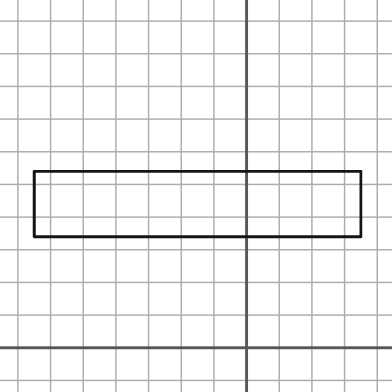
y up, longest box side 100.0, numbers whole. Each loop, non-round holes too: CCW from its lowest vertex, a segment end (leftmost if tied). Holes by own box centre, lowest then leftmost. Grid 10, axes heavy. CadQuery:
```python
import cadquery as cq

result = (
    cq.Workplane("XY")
    .moveTo(-65.0, 34.0)
    .lineTo(35.0, 34.0)
    .lineTo(35.0, 54.0)
    .lineTo(-65.0, 54.0)
    .close()
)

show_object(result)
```